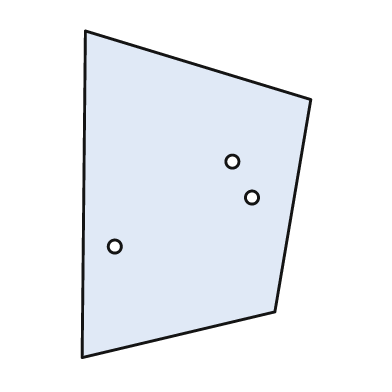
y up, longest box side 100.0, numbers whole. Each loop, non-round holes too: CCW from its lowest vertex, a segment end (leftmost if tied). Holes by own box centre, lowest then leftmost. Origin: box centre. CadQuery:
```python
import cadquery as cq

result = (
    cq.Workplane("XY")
    .moveTo(-35.0, -50.0)
    .lineTo(24.0, -36.0)
    .lineTo(35.0, 29.0)
    .lineTo(-34.0, 50.0)
    .close()
    .moveTo(-25.0, -16.0)
    .circle(2.0)
    .moveTo(17.0, -1.0)
    .circle(2.0)
    .moveTo(11.0, 10.0)
    .circle(2.0)
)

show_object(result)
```